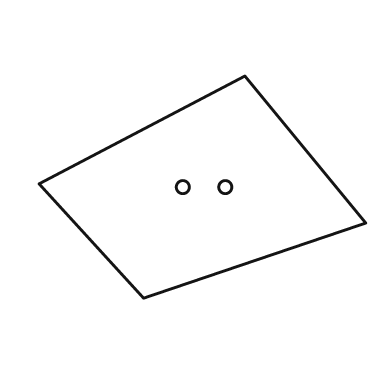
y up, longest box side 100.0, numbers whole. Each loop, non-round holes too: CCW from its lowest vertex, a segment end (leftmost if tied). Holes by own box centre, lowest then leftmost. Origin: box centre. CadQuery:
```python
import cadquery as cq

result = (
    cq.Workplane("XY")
    .moveTo(-18.0, -34.0)
    .lineTo(50.0, -11.0)
    .lineTo(13.0, 34.0)
    .lineTo(-50.0, 1.0)
    .close()
    .moveTo(-6.0, 0.0)
    .circle(2.0)
    .moveTo(7.0, 0.0)
    .circle(2.0)
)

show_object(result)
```